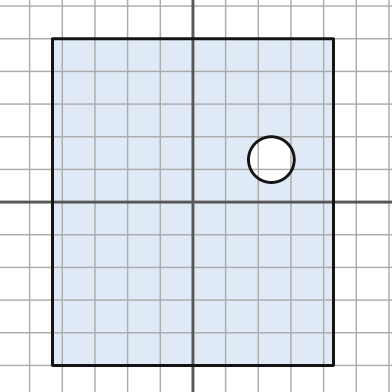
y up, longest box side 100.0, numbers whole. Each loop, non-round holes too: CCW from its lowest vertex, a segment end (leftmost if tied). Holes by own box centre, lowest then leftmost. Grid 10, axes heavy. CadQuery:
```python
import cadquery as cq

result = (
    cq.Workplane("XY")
    .moveTo(-43.0, -50.0)
    .lineTo(43.0, -50.0)
    .lineTo(43.0, 50.0)
    .lineTo(-43.0, 50.0)
    .close()
    .moveTo(24.0, 13.0)
    .circle(7.0)
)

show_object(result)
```